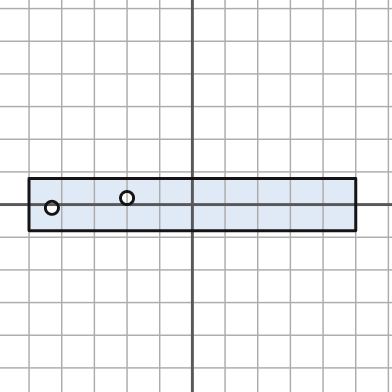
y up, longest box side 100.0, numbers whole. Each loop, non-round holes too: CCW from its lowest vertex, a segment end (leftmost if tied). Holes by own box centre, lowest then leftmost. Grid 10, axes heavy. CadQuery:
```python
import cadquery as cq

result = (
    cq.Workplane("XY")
    .moveTo(-50.0, -8.0)
    .lineTo(50.0, -8.0)
    .lineTo(50.0, 8.0)
    .lineTo(-50.0, 8.0)
    .close()
    .moveTo(-43.0, -1.0)
    .circle(2.0)
    .moveTo(-20.0, 2.0)
    .circle(2.0)
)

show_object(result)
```